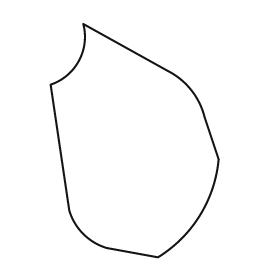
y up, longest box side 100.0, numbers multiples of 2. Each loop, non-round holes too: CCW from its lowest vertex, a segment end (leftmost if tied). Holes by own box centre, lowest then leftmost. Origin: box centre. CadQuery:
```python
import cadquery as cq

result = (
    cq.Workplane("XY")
    .moveTo(10.0, -50.0)
    .threePointArc((28.0, -32.0), (36.0, -8.0))
    .lineTo(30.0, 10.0)
    .threePointArc((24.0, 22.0), (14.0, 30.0))
    .lineTo(-22.0, 50.0)
    .threePointArc((-24.0, 34.0), (-36.0, 24.0))
    .lineTo(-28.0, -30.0)
    .threePointArc((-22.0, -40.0), (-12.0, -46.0))
    .close()
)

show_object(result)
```